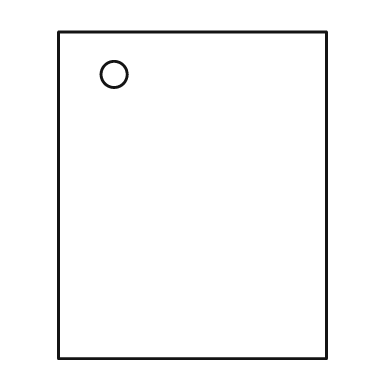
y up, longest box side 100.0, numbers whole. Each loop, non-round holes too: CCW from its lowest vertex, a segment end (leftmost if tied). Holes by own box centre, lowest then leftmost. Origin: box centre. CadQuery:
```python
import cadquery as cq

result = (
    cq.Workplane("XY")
    .moveTo(-41.0, -50.0)
    .lineTo(41.0, -50.0)
    .lineTo(41.0, 50.0)
    .lineTo(-41.0, 50.0)
    .close()
    .moveTo(-24.0, 37.0)
    .circle(4.0)
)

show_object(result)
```